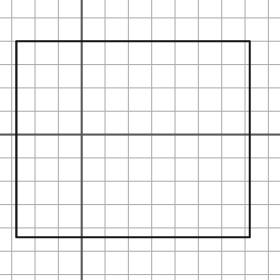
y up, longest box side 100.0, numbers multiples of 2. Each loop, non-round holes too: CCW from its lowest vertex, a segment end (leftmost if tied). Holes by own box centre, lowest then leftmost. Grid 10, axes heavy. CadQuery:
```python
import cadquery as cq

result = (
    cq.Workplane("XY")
    .moveTo(-28.0, -44.0)
    .lineTo(72.0, -44.0)
    .lineTo(72.0, 40.0)
    .lineTo(-28.0, 40.0)
    .close()
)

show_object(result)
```